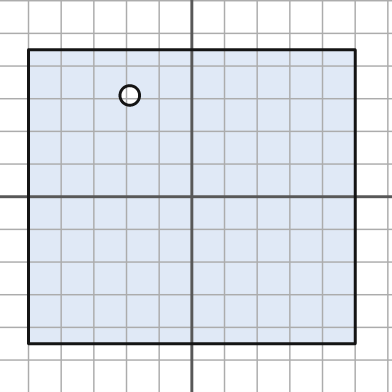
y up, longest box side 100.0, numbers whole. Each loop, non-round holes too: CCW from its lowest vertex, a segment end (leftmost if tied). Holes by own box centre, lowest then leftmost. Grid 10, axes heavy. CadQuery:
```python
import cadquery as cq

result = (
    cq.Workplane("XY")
    .moveTo(-50.0, -45.0)
    .lineTo(50.0, -45.0)
    .lineTo(50.0, 45.0)
    .lineTo(-50.0, 45.0)
    .close()
    .moveTo(-19.0, 31.0)
    .circle(3.0)
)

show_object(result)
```